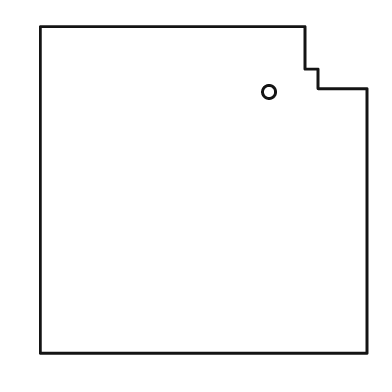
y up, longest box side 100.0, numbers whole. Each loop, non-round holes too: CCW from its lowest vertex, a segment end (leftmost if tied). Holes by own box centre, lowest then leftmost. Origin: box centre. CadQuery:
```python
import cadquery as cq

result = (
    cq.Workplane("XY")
    .moveTo(-50.0, -50.0)
    .lineTo(50.0, -50.0)
    .lineTo(50.0, 31.0)
    .lineTo(35.0, 31.0)
    .lineTo(35.0, 37.0)
    .lineTo(31.0, 37.0)
    .lineTo(31.0, 50.0)
    .lineTo(-50.0, 50.0)
    .close()
    .moveTo(20.0, 30.0)
    .circle(2.0)
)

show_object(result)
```